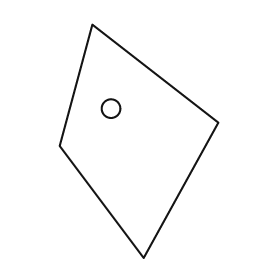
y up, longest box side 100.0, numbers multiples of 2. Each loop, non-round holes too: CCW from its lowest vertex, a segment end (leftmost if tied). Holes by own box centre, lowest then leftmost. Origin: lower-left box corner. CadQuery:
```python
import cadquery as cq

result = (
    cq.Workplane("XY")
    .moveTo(36.0, 0.0)
    .lineTo(68.0, 58.0)
    .lineTo(14.0, 100.0)
    .lineTo(0.0, 48.0)
    .close()
    .moveTo(22.0, 64.0)
    .circle(4.0)
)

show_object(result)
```